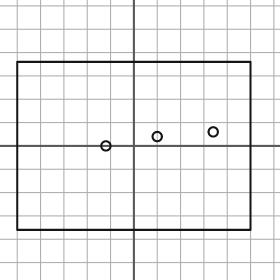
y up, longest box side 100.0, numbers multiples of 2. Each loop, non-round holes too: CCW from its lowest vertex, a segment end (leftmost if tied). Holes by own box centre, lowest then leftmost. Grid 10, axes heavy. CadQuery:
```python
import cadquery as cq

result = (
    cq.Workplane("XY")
    .moveTo(-50.0, -36.0)
    .lineTo(50.0, -36.0)
    .lineTo(50.0, 36.0)
    .lineTo(-50.0, 36.0)
    .close()
    .moveTo(-12.0, 0.0)
    .circle(2.0)
    .moveTo(10.0, 4.0)
    .circle(2.0)
    .moveTo(34.0, 6.0)
    .circle(2.0)
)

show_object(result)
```